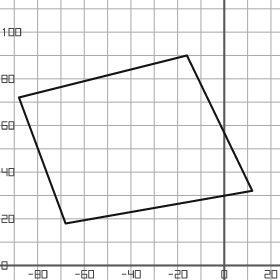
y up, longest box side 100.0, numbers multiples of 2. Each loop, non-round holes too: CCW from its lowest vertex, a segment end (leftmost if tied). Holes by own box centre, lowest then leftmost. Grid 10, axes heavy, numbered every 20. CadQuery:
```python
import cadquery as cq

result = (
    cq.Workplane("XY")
    .moveTo(-68.0, 18.0)
    .lineTo(12.0, 32.0)
    .lineTo(-16.0, 90.0)
    .lineTo(-88.0, 72.0)
    .close()
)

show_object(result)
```